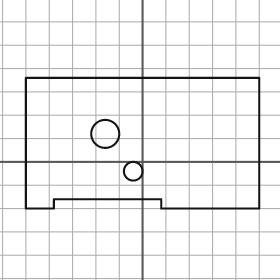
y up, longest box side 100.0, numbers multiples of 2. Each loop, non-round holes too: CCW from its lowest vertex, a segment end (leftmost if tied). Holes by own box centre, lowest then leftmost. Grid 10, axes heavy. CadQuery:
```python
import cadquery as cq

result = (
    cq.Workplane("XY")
    .moveTo(-50.0, -20.0)
    .lineTo(-38.0, -20.0)
    .lineTo(-38.0, -16.0)
    .lineTo(8.0, -16.0)
    .lineTo(8.0, -20.0)
    .lineTo(50.0, -20.0)
    .lineTo(50.0, 36.0)
    .lineTo(-50.0, 36.0)
    .close()
    .moveTo(-4.0, -4.0)
    .circle(4.0)
    .moveTo(-16.0, 12.0)
    .circle(6.0)
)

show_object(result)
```